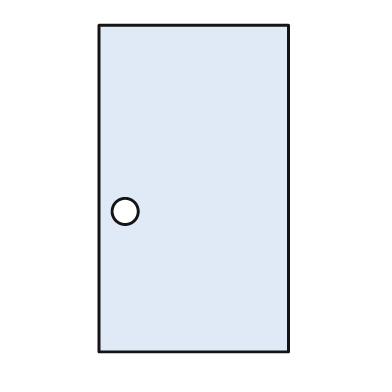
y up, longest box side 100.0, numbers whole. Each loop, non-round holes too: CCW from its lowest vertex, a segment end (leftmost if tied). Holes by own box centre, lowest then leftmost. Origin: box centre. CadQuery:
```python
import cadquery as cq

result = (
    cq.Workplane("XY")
    .moveTo(-29.0, -50.0)
    .lineTo(29.0, -50.0)
    .lineTo(29.0, 50.0)
    .lineTo(-29.0, 50.0)
    .close()
    .moveTo(-21.0, -7.0)
    .circle(4.0)
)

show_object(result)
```